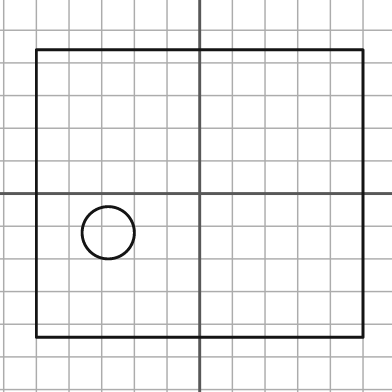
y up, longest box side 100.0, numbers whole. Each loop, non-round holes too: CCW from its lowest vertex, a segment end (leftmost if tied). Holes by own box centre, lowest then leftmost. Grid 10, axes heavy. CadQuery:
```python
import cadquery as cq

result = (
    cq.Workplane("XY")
    .moveTo(-50.0, -44.0)
    .lineTo(50.0, -44.0)
    .lineTo(50.0, 44.0)
    .lineTo(-50.0, 44.0)
    .close()
    .moveTo(-28.0, -12.0)
    .circle(8.0)
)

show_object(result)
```